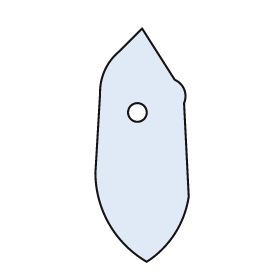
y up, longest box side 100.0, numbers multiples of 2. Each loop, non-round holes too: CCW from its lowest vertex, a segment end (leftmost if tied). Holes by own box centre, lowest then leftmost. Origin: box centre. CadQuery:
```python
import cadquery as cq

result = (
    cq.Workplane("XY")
    .moveTo(2.0, -50.0)
    .threePointArc((14.0, -38.0), (20.0, -22.0))
    .lineTo(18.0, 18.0)
    .threePointArc((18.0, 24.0), (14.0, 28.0))
    .lineTo(0.0, 50.0)
    .lineTo(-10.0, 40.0)
    .threePointArc((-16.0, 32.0), (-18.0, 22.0))
    .lineTo(-20.0, -12.0)
    .threePointArc((-14.0, -34.0), (2.0, -50.0))
    .close()
    .moveTo(-2.0, 14.0)
    .circle(4.0)
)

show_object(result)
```